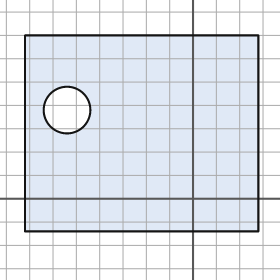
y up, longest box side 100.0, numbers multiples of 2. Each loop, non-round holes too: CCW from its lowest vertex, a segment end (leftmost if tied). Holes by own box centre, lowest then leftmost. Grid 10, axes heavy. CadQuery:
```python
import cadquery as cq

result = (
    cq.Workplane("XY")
    .moveTo(-72.0, -14.0)
    .lineTo(28.0, -14.0)
    .lineTo(28.0, 70.0)
    .lineTo(-72.0, 70.0)
    .close()
    .moveTo(-54.0, 38.0)
    .circle(10.0)
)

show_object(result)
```